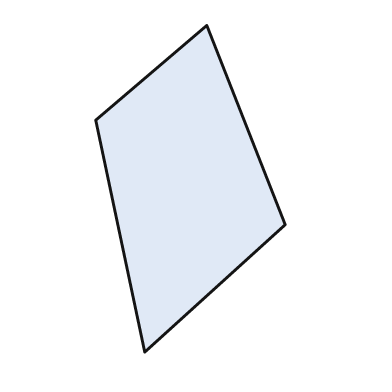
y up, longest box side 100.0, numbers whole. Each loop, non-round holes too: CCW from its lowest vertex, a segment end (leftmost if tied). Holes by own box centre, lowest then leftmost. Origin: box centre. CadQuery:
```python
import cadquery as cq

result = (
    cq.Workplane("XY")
    .moveTo(-14.0, -50.0)
    .lineTo(29.0, -11.0)
    .lineTo(5.0, 50.0)
    .lineTo(-29.0, 21.0)
    .close()
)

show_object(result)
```